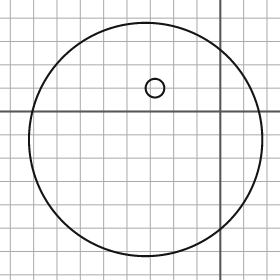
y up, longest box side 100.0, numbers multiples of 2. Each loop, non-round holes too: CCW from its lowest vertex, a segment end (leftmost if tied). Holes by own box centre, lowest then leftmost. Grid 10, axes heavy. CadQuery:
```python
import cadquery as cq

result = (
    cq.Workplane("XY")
    .moveTo(-32.0, -12.0)
    .circle(50.0)
    .moveTo(-28.0, 10.0)
    .circle(4.0)
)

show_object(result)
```